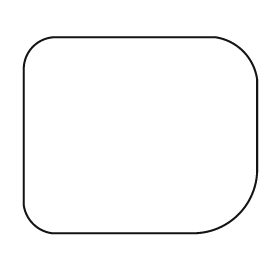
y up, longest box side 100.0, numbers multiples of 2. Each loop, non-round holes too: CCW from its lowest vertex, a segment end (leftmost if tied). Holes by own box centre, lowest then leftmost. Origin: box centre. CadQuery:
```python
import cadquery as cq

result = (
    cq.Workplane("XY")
    .moveTo(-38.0, -42.0)
    .lineTo(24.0, -42.0)
    .threePointArc((42.0, -34.0), (50.0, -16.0))
    .lineTo(50.0, 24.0)
    .threePointArc((44.0, 36.0), (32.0, 42.0))
    .lineTo(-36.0, 42.0)
    .threePointArc((-46.0, 38.0), (-50.0, 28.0))
    .lineTo(-50.0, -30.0)
    .threePointArc((-46.0, -38.0), (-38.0, -42.0))
    .close()
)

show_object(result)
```